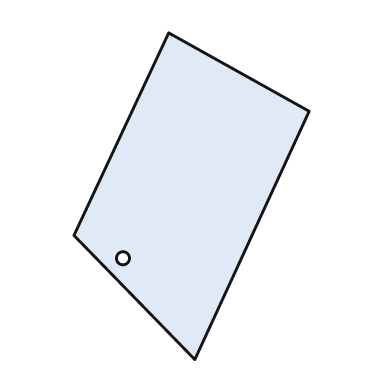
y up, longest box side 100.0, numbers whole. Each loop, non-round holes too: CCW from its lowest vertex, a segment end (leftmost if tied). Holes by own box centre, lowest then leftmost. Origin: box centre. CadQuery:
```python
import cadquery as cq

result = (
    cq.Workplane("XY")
    .moveTo(1.0, -50.0)
    .lineTo(36.0, 26.0)
    .lineTo(-7.0, 50.0)
    .lineTo(-36.0, -12.0)
    .close()
    .moveTo(-21.0, -19.0)
    .circle(2.0)
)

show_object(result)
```